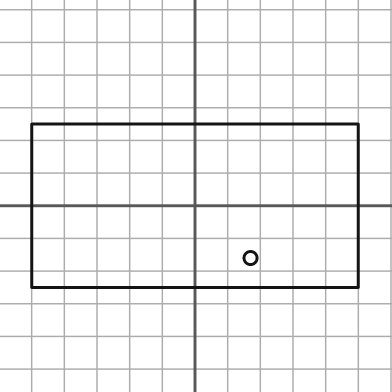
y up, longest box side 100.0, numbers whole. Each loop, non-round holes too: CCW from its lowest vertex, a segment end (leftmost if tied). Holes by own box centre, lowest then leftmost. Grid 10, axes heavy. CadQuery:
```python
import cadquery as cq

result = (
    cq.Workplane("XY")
    .moveTo(-50.0, -25.0)
    .lineTo(50.0, -25.0)
    .lineTo(50.0, 25.0)
    .lineTo(-50.0, 25.0)
    .close()
    .moveTo(17.0, -16.0)
    .circle(2.0)
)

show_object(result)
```